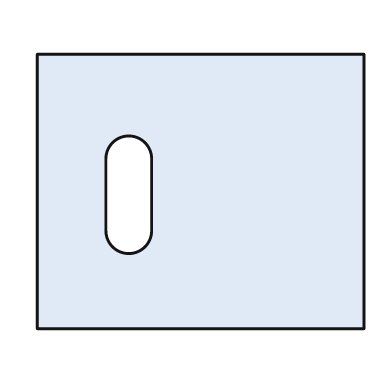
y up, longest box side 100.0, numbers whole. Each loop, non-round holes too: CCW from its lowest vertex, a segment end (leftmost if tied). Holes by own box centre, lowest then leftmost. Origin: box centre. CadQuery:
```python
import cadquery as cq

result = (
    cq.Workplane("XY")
    .moveTo(-50.0, -42.0)
    .lineTo(50.0, -42.0)
    .lineTo(50.0, 42.0)
    .lineTo(-50.0, 42.0)
    .close()
    .moveTo(-29.0, -12.0)
    .threePointArc((-22.0, -19.0), (-15.0, -12.0))
    .lineTo(-15.0, 10.0)
    .threePointArc((-22.0, 17.0), (-29.0, 10.0))
    .close()
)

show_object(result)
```